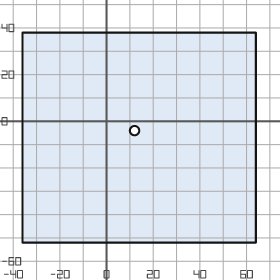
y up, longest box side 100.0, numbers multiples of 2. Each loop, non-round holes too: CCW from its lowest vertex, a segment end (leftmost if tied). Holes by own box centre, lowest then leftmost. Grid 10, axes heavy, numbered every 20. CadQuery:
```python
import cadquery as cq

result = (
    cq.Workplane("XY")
    .moveTo(-36.0, -52.0)
    .lineTo(64.0, -52.0)
    .lineTo(64.0, 38.0)
    .lineTo(-36.0, 38.0)
    .close()
    .moveTo(12.0, -4.0)
    .circle(2.0)
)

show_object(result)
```